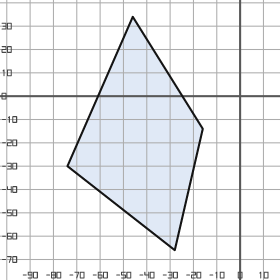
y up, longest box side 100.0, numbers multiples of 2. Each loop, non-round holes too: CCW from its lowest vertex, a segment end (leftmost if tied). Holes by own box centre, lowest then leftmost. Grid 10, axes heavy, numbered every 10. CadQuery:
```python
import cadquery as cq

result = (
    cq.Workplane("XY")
    .moveTo(-28.0, -66.0)
    .lineTo(-16.0, -14.0)
    .lineTo(-46.0, 34.0)
    .lineTo(-74.0, -30.0)
    .close()
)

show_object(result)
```